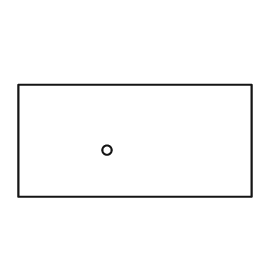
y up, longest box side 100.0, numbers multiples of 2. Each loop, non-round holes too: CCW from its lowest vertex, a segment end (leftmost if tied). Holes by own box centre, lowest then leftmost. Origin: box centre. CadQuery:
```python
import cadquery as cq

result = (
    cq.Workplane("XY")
    .moveTo(-50.0, -24.0)
    .lineTo(50.0, -24.0)
    .lineTo(50.0, 24.0)
    .lineTo(-50.0, 24.0)
    .close()
    .moveTo(-12.0, -4.0)
    .circle(2.0)
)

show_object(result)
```